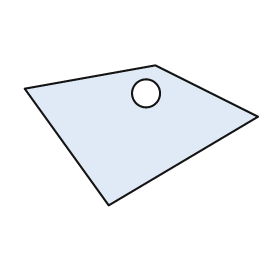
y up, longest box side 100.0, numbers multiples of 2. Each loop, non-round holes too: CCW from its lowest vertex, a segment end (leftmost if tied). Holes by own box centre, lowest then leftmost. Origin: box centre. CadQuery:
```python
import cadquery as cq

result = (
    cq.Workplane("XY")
    .moveTo(-14.0, -30.0)
    .lineTo(50.0, 8.0)
    .lineTo(6.0, 30.0)
    .lineTo(-50.0, 20.0)
    .close()
    .moveTo(2.0, 18.0)
    .circle(6.0)
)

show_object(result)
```